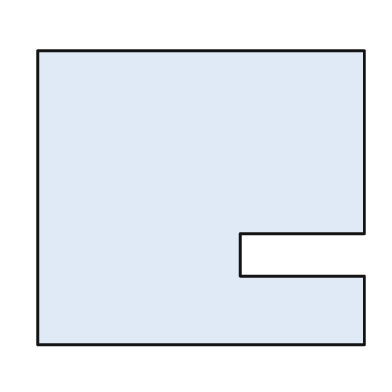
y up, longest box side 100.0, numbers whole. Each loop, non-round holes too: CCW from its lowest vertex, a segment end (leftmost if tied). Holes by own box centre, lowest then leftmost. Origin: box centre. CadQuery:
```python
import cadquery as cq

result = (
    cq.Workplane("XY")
    .moveTo(-50.0, -45.0)
    .lineTo(50.0, -45.0)
    .lineTo(50.0, -24.0)
    .lineTo(12.0, -24.0)
    .lineTo(12.0, -11.0)
    .lineTo(50.0, -11.0)
    .lineTo(50.0, 45.0)
    .lineTo(-50.0, 45.0)
    .close()
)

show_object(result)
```